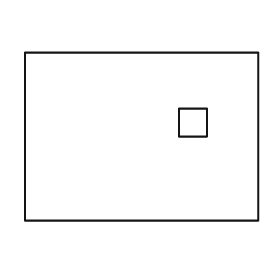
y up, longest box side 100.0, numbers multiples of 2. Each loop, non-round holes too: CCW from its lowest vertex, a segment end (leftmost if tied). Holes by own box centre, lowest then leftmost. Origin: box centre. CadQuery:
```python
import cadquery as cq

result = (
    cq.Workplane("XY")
    .moveTo(-50.0, -36.0)
    .lineTo(50.0, -36.0)
    .lineTo(50.0, 36.0)
    .lineTo(-50.0, 36.0)
    .close()
    .moveTo(16.0, 0.0)
    .lineTo(28.0, 0.0)
    .lineTo(28.0, 12.0)
    .lineTo(16.0, 12.0)
    .close()
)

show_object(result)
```